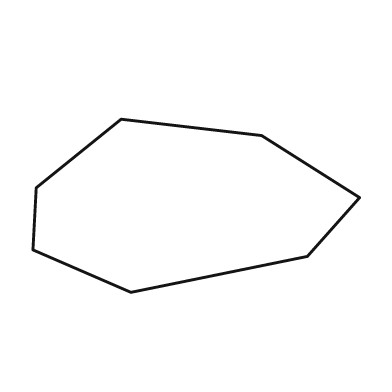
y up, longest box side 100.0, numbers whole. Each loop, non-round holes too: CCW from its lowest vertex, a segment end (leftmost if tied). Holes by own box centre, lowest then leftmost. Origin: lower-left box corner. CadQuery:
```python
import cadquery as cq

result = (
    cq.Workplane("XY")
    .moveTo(30.0, 0.0)
    .lineTo(84.0, 11.0)
    .lineTo(100.0, 29.0)
    .lineTo(70.0, 48.0)
    .lineTo(27.0, 53.0)
    .lineTo(1.0, 32.0)
    .lineTo(0.0, 13.0)
    .close()
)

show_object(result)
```